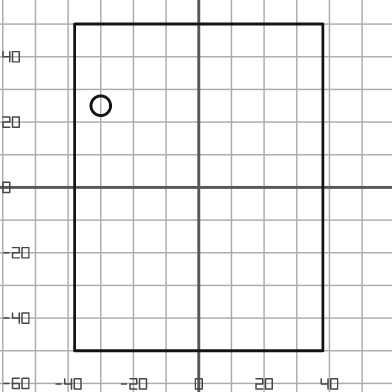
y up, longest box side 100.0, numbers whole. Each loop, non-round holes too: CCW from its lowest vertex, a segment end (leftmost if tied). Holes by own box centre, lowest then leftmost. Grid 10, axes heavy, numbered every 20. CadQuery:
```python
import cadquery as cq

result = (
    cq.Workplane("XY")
    .moveTo(-38.0, -50.0)
    .lineTo(38.0, -50.0)
    .lineTo(38.0, 50.0)
    .lineTo(-38.0, 50.0)
    .close()
    .moveTo(-30.0, 25.0)
    .circle(3.0)
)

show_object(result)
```